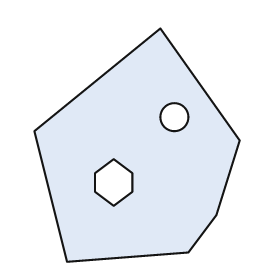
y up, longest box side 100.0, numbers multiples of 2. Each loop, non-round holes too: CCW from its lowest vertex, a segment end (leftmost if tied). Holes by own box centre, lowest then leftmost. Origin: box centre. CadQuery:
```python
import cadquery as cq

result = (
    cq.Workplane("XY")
    .moveTo(-30.0, -50.0)
    .lineTo(22.0, -46.0)
    .lineTo(34.0, -30.0)
    .lineTo(44.0, 2.0)
    .lineTo(10.0, 50.0)
    .lineTo(-44.0, 6.0)
    .close()
    .moveTo(-10.0, -26.0)
    .lineTo(-2.0, -20.0)
    .lineTo(-2.0, -12.0)
    .lineTo(-10.0, -6.0)
    .lineTo(-18.0, -12.0)
    .lineTo(-18.0, -20.0)
    .close()
    .moveTo(16.0, 12.0)
    .circle(6.0)
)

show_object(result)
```